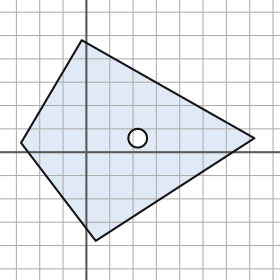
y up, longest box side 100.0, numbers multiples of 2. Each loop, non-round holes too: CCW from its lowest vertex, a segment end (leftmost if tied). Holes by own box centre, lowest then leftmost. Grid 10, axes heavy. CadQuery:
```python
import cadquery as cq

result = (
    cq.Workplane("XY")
    .moveTo(4.0, -38.0)
    .lineTo(72.0, 6.0)
    .lineTo(-2.0, 48.0)
    .lineTo(-28.0, 4.0)
    .close()
    .moveTo(22.0, 6.0)
    .circle(4.0)
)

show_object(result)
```